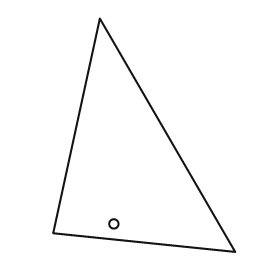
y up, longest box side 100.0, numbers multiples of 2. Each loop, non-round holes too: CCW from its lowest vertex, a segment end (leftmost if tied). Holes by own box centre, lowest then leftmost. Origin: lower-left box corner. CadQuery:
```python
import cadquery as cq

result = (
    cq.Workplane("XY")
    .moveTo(78.0, 0.0)
    .lineTo(20.0, 100.0)
    .lineTo(0.0, 8.0)
    .close()
    .moveTo(26.0, 12.0)
    .circle(2.0)
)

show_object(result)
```